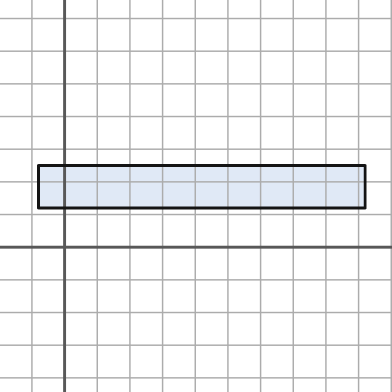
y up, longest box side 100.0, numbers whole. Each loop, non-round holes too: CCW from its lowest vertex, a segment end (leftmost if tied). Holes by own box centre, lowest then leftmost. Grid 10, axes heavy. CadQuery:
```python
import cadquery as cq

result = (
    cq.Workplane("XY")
    .moveTo(-8.0, 12.0)
    .lineTo(92.0, 12.0)
    .lineTo(92.0, 25.0)
    .lineTo(-8.0, 25.0)
    .close()
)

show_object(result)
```